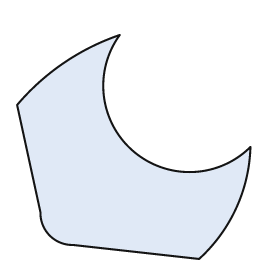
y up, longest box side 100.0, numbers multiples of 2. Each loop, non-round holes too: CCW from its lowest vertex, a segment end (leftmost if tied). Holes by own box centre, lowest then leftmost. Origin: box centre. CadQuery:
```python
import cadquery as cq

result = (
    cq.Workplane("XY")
    .moveTo(28.0, -48.0)
    .threePointArc((44.0, -26.0), (50.0, 0.0))
    .threePointArc((0.0, -2.0), (-6.0, 48.0))
    .threePointArc((-30.0, 36.0), (-50.0, 18.0))
    .lineTo(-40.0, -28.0)
    .threePointArc((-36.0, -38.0), (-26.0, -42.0))
    .close()
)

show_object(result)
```